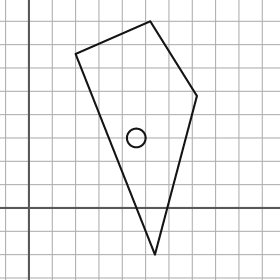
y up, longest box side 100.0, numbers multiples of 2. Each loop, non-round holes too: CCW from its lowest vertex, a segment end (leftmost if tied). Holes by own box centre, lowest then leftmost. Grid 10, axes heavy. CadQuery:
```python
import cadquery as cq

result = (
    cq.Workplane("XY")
    .moveTo(54.0, -20.0)
    .lineTo(72.0, 48.0)
    .lineTo(52.0, 80.0)
    .lineTo(20.0, 66.0)
    .close()
    .moveTo(46.0, 30.0)
    .circle(4.0)
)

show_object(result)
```